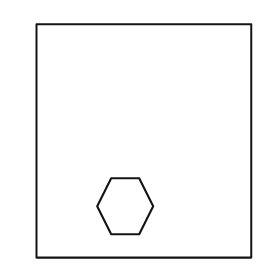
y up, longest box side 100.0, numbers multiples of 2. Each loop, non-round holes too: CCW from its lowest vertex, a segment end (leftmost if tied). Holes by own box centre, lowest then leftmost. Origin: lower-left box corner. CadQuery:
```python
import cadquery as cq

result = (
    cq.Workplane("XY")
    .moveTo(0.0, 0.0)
    .lineTo(92.0, 0.0)
    .lineTo(92.0, 100.0)
    .lineTo(0.0, 100.0)
    .close()
    .moveTo(32.0, 10.0)
    .lineTo(44.0, 10.0)
    .lineTo(50.0, 22.0)
    .lineTo(44.0, 34.0)
    .lineTo(32.0, 34.0)
    .lineTo(26.0, 22.0)
    .close()
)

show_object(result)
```